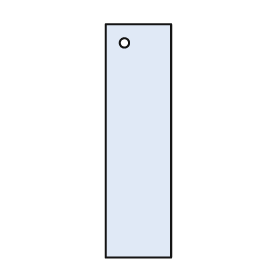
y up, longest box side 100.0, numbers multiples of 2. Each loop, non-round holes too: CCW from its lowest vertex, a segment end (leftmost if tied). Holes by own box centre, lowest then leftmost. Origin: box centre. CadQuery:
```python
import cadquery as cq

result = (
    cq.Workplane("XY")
    .moveTo(-14.0, -50.0)
    .lineTo(14.0, -50.0)
    .lineTo(14.0, 50.0)
    .lineTo(-14.0, 50.0)
    .close()
    .moveTo(-6.0, 42.0)
    .circle(2.0)
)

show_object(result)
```